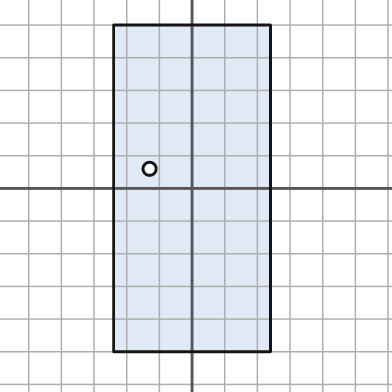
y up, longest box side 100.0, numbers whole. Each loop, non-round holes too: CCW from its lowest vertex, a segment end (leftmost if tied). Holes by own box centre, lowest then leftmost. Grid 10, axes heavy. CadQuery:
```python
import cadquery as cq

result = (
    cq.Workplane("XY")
    .moveTo(-24.0, -50.0)
    .lineTo(24.0, -50.0)
    .lineTo(24.0, 50.0)
    .lineTo(-24.0, 50.0)
    .close()
    .moveTo(-13.0, 6.0)
    .circle(2.0)
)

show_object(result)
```